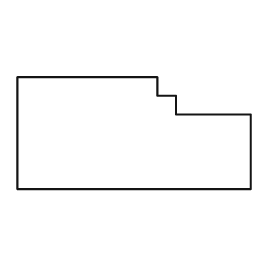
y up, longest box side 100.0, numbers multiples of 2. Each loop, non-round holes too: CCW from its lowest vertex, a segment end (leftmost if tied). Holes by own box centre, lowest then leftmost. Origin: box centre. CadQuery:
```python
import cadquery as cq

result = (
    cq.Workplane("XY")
    .moveTo(-50.0, -24.0)
    .lineTo(50.0, -24.0)
    .lineTo(50.0, 8.0)
    .lineTo(18.0, 8.0)
    .lineTo(18.0, 16.0)
    .lineTo(10.0, 16.0)
    .lineTo(10.0, 24.0)
    .lineTo(-50.0, 24.0)
    .close()
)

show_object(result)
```